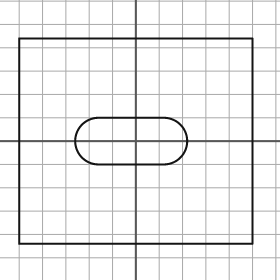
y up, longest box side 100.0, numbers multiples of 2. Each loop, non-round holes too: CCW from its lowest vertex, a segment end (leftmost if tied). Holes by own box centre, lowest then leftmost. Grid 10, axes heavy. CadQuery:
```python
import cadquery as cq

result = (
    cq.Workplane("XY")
    .moveTo(-50.0, -44.0)
    .lineTo(50.0, -44.0)
    .lineTo(50.0, 44.0)
    .lineTo(-50.0, 44.0)
    .close()
    .moveTo(-16.0, -10.0)
    .lineTo(12.0, -10.0)
    .threePointArc((22.0, 0.0), (12.0, 10.0))
    .lineTo(-16.0, 10.0)
    .threePointArc((-26.0, 0.0), (-16.0, -10.0))
    .close()
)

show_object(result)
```